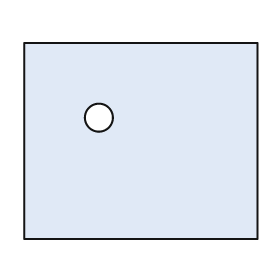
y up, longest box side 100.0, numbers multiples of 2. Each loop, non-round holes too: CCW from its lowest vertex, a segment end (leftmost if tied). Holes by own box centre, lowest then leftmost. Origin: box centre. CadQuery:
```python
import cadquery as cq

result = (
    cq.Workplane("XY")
    .moveTo(-50.0, -42.0)
    .lineTo(50.0, -42.0)
    .lineTo(50.0, 42.0)
    .lineTo(-50.0, 42.0)
    .close()
    .moveTo(-18.0, 10.0)
    .circle(6.0)
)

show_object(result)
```